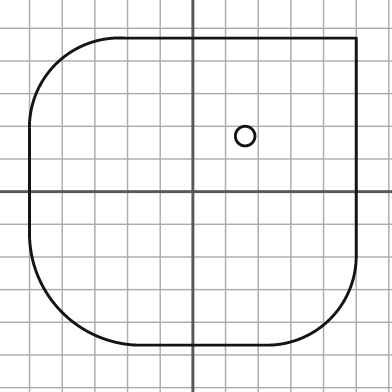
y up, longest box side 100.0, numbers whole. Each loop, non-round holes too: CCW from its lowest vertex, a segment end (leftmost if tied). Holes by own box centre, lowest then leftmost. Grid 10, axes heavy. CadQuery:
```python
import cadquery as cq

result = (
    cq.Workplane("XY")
    .moveTo(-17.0, -47.0)
    .lineTo(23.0, -47.0)
    .threePointArc((42.0, -39.0), (50.0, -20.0))
    .lineTo(50.0, 47.0)
    .lineTo(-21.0, 47.0)
    .threePointArc((-42.0, 39.0), (-50.0, 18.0))
    .lineTo(-50.0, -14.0)
    .threePointArc((-40.0, -37.0), (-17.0, -47.0))
    .close()
    .moveTo(16.0, 17.0)
    .circle(3.0)
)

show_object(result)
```